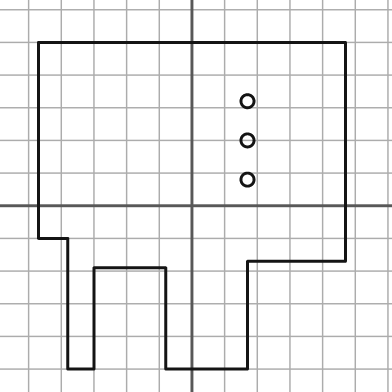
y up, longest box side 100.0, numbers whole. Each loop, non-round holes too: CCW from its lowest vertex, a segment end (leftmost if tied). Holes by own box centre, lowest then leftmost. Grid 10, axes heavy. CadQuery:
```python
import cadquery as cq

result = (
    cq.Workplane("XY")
    .moveTo(-38.0, -50.0)
    .lineTo(-30.0, -50.0)
    .lineTo(-30.0, -19.0)
    .lineTo(-8.0, -19.0)
    .lineTo(-8.0, -50.0)
    .lineTo(17.0, -50.0)
    .lineTo(17.0, -17.0)
    .lineTo(47.0, -17.0)
    .lineTo(47.0, 50.0)
    .lineTo(-47.0, 50.0)
    .lineTo(-47.0, -10.0)
    .lineTo(-38.0, -10.0)
    .close()
    .moveTo(17.0, 8.0)
    .circle(2.0)
    .moveTo(17.0, 20.0)
    .circle(2.0)
    .moveTo(17.0, 32.0)
    .circle(2.0)
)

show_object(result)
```